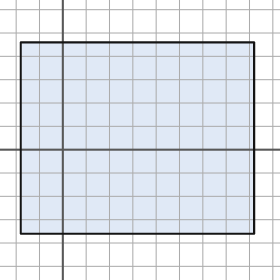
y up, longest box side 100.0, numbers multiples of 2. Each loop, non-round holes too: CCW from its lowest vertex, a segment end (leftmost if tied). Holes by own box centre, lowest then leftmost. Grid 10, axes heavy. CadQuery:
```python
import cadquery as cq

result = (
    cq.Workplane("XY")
    .moveTo(-18.0, -36.0)
    .lineTo(82.0, -36.0)
    .lineTo(82.0, 46.0)
    .lineTo(-18.0, 46.0)
    .close()
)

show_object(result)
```